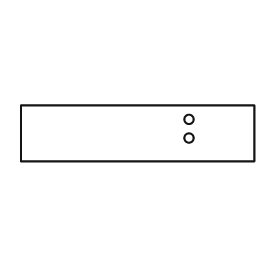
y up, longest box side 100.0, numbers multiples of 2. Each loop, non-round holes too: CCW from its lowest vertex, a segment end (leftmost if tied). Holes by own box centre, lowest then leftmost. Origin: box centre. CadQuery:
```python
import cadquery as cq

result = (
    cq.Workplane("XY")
    .moveTo(-50.0, -12.0)
    .lineTo(50.0, -12.0)
    .lineTo(50.0, 12.0)
    .lineTo(-50.0, 12.0)
    .close()
    .moveTo(22.0, -2.0)
    .circle(2.0)
    .moveTo(22.0, 6.0)
    .circle(2.0)
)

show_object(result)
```